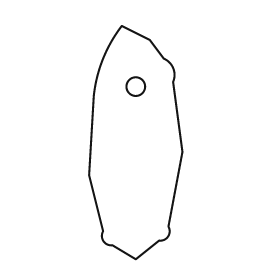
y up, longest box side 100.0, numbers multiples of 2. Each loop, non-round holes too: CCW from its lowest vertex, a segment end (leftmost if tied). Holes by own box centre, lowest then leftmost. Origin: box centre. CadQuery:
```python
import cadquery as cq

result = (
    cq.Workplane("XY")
    .moveTo(0.0, -50.0)
    .lineTo(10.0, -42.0)
    .threePointArc((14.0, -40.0), (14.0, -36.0))
    .lineTo(20.0, -4.0)
    .lineTo(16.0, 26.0)
    .threePointArc((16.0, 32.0), (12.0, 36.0))
    .lineTo(6.0, 44.0)
    .lineTo(-6.0, 50.0)
    .threePointArc((-14.0, 36.0), (-18.0, 20.0))
    .lineTo(-20.0, -14.0)
    .lineTo(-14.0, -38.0)
    .threePointArc((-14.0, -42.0), (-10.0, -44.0))
    .close()
    .moveTo(0.0, 24.0)
    .circle(4.0)
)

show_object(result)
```